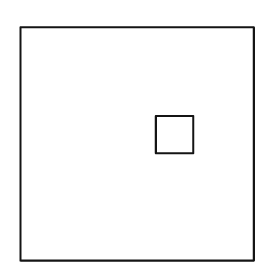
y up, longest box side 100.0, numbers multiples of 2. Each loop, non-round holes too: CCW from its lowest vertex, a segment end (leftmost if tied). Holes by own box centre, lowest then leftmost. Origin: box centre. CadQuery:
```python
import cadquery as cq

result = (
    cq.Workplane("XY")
    .moveTo(-50.0, -50.0)
    .lineTo(50.0, -50.0)
    .lineTo(50.0, 50.0)
    .lineTo(-50.0, 50.0)
    .close()
    .moveTo(8.0, -4.0)
    .lineTo(24.0, -4.0)
    .lineTo(24.0, 12.0)
    .lineTo(8.0, 12.0)
    .close()
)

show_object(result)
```